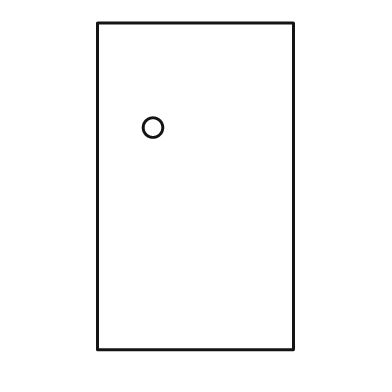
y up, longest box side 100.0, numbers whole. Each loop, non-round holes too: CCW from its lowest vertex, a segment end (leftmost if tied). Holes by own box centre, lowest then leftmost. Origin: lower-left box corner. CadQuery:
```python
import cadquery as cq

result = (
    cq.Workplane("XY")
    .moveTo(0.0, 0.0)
    .lineTo(60.0, 0.0)
    .lineTo(60.0, 100.0)
    .lineTo(0.0, 100.0)
    .close()
    .moveTo(17.0, 68.0)
    .circle(3.0)
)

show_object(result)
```